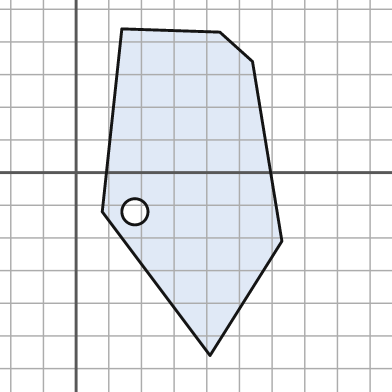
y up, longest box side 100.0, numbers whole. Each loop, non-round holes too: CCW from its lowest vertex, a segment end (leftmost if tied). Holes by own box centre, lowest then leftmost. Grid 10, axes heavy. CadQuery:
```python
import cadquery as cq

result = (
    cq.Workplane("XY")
    .moveTo(41.0, -56.0)
    .lineTo(63.0, -21.0)
    .lineTo(54.0, 34.0)
    .lineTo(44.0, 43.0)
    .lineTo(14.0, 44.0)
    .lineTo(8.0, -12.0)
    .close()
    .moveTo(18.0, -12.0)
    .circle(4.0)
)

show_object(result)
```